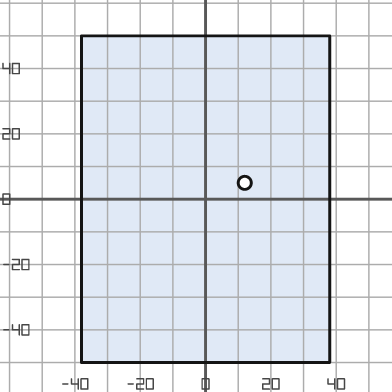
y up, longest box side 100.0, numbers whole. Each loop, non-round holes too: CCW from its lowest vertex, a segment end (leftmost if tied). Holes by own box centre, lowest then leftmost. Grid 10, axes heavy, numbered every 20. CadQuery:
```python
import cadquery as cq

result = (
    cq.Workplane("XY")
    .moveTo(-38.0, -50.0)
    .lineTo(38.0, -50.0)
    .lineTo(38.0, 50.0)
    .lineTo(-38.0, 50.0)
    .close()
    .moveTo(12.0, 5.0)
    .circle(2.0)
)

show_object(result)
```